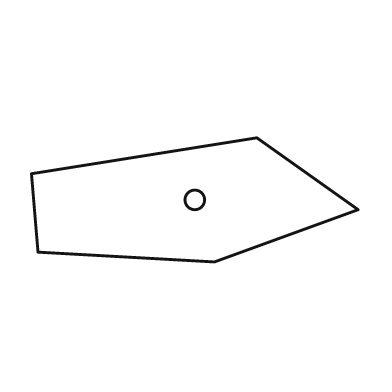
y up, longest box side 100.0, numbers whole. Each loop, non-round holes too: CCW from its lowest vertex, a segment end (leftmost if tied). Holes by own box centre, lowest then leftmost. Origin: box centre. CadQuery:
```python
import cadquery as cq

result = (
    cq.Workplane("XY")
    .moveTo(6.0, -19.0)
    .lineTo(50.0, -3.0)
    .lineTo(19.0, 19.0)
    .lineTo(-50.0, 8.0)
    .lineTo(-48.0, -16.0)
    .close()
    .moveTo(0.0, 0.0)
    .circle(3.0)
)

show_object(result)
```